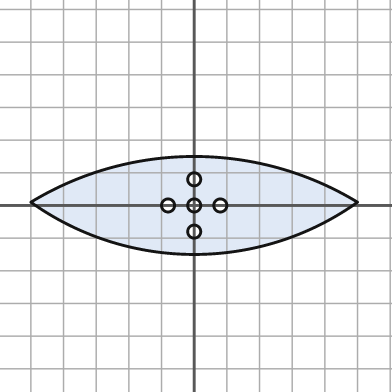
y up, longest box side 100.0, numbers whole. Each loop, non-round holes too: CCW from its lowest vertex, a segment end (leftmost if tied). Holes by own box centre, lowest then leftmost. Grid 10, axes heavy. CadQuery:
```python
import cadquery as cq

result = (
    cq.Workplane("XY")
    .moveTo(-50.0, 1.0)
    .threePointArc((0.0, -15.0), (50.0, 1.0))
    .threePointArc((0.0, 15.0), (-50.0, 1.0))
    .close()
    .moveTo(0.0, -8.0)
    .circle(2.0)
    .moveTo(-8.0, 0.0)
    .circle(2.0)
    .moveTo(0.0, 0.0)
    .circle(2.0)
    .moveTo(8.0, 0.0)
    .circle(2.0)
    .moveTo(0.0, 8.0)
    .circle(2.0)
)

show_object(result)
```